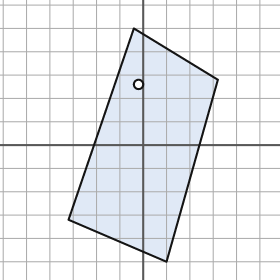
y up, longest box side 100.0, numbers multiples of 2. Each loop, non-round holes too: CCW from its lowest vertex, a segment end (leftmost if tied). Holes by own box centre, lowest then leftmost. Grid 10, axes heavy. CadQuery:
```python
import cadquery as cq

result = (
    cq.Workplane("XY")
    .moveTo(10.0, -50.0)
    .lineTo(32.0, 28.0)
    .lineTo(-4.0, 50.0)
    .lineTo(-32.0, -32.0)
    .close()
    .moveTo(-2.0, 26.0)
    .circle(2.0)
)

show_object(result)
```